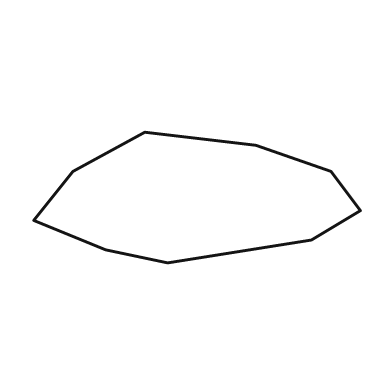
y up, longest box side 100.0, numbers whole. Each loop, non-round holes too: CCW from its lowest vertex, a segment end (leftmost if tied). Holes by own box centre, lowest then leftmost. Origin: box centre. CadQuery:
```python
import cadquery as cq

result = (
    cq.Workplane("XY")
    .moveTo(-9.0, -20.0)
    .lineTo(35.0, -13.0)
    .lineTo(50.0, -4.0)
    .lineTo(41.0, 8.0)
    .lineTo(18.0, 16.0)
    .lineTo(-16.0, 20.0)
    .lineTo(-38.0, 8.0)
    .lineTo(-50.0, -7.0)
    .lineTo(-28.0, -16.0)
    .close()
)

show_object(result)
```